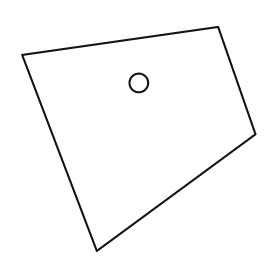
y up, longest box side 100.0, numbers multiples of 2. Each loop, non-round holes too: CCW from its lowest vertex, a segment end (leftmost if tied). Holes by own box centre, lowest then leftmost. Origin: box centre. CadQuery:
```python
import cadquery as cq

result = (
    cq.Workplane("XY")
    .moveTo(-18.0, -48.0)
    .lineTo(50.0, 2.0)
    .lineTo(34.0, 48.0)
    .lineTo(-50.0, 36.0)
    .close()
    .moveTo(0.0, 24.0)
    .circle(4.0)
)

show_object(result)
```